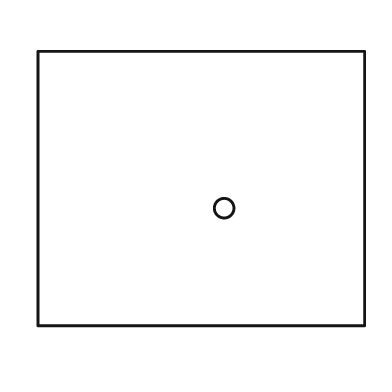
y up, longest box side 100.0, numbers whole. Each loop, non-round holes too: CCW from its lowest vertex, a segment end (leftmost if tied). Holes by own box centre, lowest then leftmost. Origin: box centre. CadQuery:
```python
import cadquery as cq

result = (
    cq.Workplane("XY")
    .moveTo(-50.0, -42.0)
    .lineTo(50.0, -42.0)
    .lineTo(50.0, 42.0)
    .lineTo(-50.0, 42.0)
    .close()
    .moveTo(7.0, -6.0)
    .circle(3.0)
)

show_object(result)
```